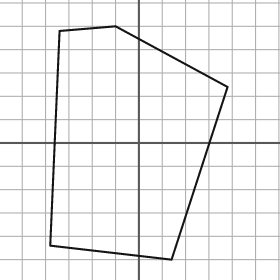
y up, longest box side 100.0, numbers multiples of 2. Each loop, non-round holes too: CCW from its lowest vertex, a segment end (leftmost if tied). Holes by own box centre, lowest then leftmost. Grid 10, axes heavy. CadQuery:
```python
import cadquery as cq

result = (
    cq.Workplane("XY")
    .moveTo(14.0, -50.0)
    .lineTo(38.0, 24.0)
    .lineTo(-10.0, 50.0)
    .lineTo(-34.0, 48.0)
    .lineTo(-38.0, -44.0)
    .close()
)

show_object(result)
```